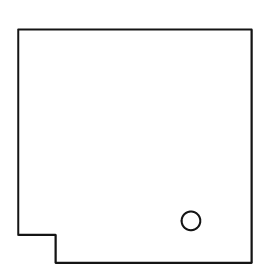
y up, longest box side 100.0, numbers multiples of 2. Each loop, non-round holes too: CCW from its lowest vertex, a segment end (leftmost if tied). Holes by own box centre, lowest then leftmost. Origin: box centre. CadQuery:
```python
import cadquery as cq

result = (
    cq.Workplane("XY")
    .moveTo(-34.0, -50.0)
    .lineTo(50.0, -50.0)
    .lineTo(50.0, 50.0)
    .lineTo(-50.0, 50.0)
    .lineTo(-50.0, -38.0)
    .lineTo(-34.0, -38.0)
    .close()
    .moveTo(24.0, -32.0)
    .circle(4.0)
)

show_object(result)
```